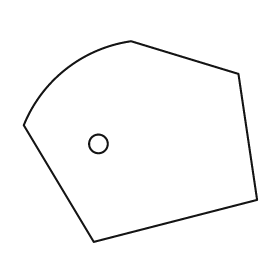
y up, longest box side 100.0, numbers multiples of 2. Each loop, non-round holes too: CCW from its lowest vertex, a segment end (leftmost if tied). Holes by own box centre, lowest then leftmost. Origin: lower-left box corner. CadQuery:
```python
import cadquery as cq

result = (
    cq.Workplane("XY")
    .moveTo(30.0, 0.0)
    .lineTo(100.0, 18.0)
    .lineTo(92.0, 72.0)
    .lineTo(46.0, 86.0)
    .threePointArc((18.0, 74.0), (0.0, 50.0))
    .close()
    .moveTo(32.0, 42.0)
    .circle(4.0)
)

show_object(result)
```